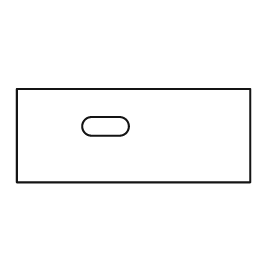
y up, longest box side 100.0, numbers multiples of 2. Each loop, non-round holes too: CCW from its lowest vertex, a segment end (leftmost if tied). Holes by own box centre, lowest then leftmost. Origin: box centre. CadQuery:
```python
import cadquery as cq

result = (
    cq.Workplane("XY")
    .moveTo(-50.0, -20.0)
    .lineTo(50.0, -20.0)
    .lineTo(50.0, 20.0)
    .lineTo(-50.0, 20.0)
    .close()
    .moveTo(-18.0, 0.0)
    .lineTo(-6.0, 0.0)
    .threePointArc((-2.0, 4.0), (-6.0, 8.0))
    .lineTo(-18.0, 8.0)
    .threePointArc((-22.0, 4.0), (-18.0, 0.0))
    .close()
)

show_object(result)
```